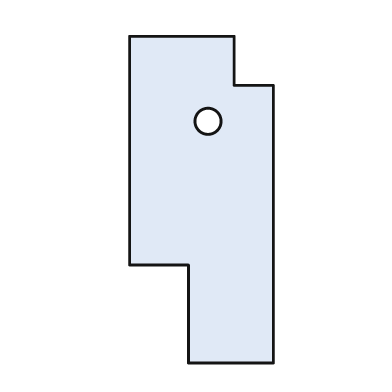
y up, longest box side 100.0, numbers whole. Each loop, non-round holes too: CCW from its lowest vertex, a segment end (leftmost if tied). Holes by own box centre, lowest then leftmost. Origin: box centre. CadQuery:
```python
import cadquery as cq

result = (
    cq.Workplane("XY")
    .moveTo(-4.0, -50.0)
    .lineTo(22.0, -50.0)
    .lineTo(22.0, 35.0)
    .lineTo(10.0, 35.0)
    .lineTo(10.0, 50.0)
    .lineTo(-22.0, 50.0)
    .lineTo(-22.0, -20.0)
    .lineTo(-4.0, -20.0)
    .close()
    .moveTo(2.0, 24.0)
    .circle(4.0)
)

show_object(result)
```